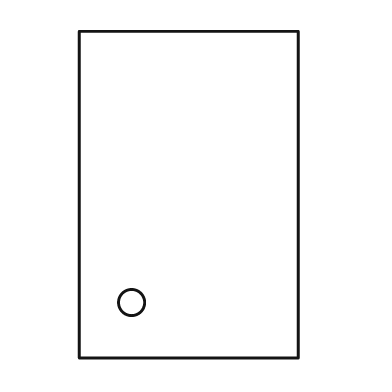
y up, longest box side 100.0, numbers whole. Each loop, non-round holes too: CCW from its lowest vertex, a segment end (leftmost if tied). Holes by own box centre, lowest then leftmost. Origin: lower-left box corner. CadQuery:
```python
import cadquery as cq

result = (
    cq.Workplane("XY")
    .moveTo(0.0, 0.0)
    .lineTo(67.0, 0.0)
    .lineTo(67.0, 100.0)
    .lineTo(0.0, 100.0)
    .close()
    .moveTo(16.0, 17.0)
    .circle(4.0)
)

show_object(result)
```